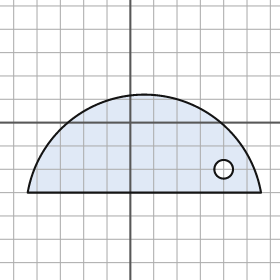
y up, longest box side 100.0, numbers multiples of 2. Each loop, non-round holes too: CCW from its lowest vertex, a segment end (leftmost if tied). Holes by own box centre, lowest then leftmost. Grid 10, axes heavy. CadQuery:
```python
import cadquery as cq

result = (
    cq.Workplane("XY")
    .moveTo(-44.0, -30.0)
    .lineTo(56.0, -30.0)
    .threePointArc((6.0, 12.0), (-44.0, -30.0))
    .close()
    .moveTo(40.0, -20.0)
    .circle(4.0)
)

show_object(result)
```